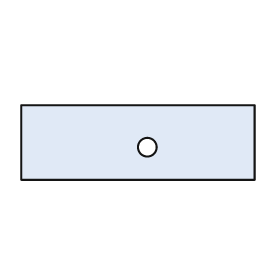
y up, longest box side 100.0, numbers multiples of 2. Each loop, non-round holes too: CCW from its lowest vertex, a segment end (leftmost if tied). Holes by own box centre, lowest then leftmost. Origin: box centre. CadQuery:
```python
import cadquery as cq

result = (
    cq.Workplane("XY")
    .moveTo(-50.0, -16.0)
    .lineTo(50.0, -16.0)
    .lineTo(50.0, 16.0)
    .lineTo(-50.0, 16.0)
    .close()
    .moveTo(4.0, -2.0)
    .circle(4.0)
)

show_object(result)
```